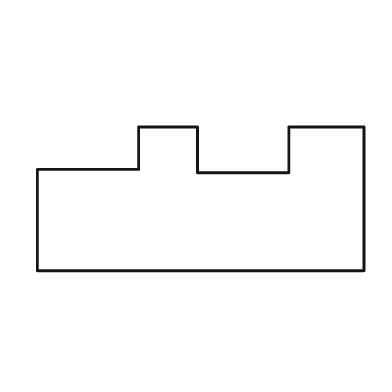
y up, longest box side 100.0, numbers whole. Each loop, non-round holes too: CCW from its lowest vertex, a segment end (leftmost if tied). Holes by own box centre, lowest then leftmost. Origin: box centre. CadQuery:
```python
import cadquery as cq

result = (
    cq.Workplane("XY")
    .moveTo(-50.0, -22.0)
    .lineTo(50.0, -22.0)
    .lineTo(50.0, 22.0)
    .lineTo(27.0, 22.0)
    .lineTo(27.0, 8.0)
    .lineTo(-1.0, 8.0)
    .lineTo(-1.0, 22.0)
    .lineTo(-19.0, 22.0)
    .lineTo(-19.0, 9.0)
    .lineTo(-50.0, 9.0)
    .close()
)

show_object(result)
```